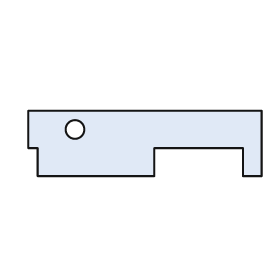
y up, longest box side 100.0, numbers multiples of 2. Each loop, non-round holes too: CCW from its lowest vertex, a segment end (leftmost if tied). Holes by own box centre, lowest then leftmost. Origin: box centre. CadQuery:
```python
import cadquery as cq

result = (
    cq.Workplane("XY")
    .moveTo(-46.0, -14.0)
    .lineTo(4.0, -14.0)
    .lineTo(4.0, -2.0)
    .lineTo(42.0, -2.0)
    .lineTo(42.0, -14.0)
    .lineTo(50.0, -14.0)
    .lineTo(50.0, 14.0)
    .lineTo(-50.0, 14.0)
    .lineTo(-50.0, -2.0)
    .lineTo(-46.0, -2.0)
    .close()
    .moveTo(-30.0, 6.0)
    .circle(4.0)
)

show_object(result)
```